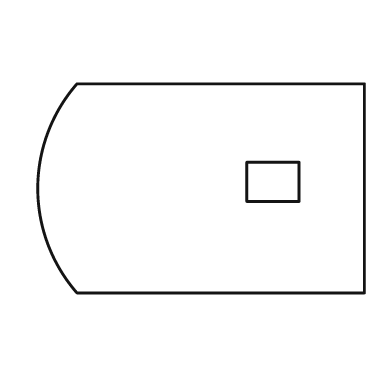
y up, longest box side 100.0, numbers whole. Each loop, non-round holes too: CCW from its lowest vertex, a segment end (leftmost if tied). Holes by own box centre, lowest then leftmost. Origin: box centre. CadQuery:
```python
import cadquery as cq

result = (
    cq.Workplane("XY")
    .moveTo(-38.0, -32.0)
    .lineTo(50.0, -32.0)
    .lineTo(50.0, 32.0)
    .lineTo(-38.0, 32.0)
    .threePointArc((-50.0, 0.0), (-38.0, -32.0))
    .close()
    .moveTo(14.0, -4.0)
    .lineTo(30.0, -4.0)
    .lineTo(30.0, 8.0)
    .lineTo(14.0, 8.0)
    .close()
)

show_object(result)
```